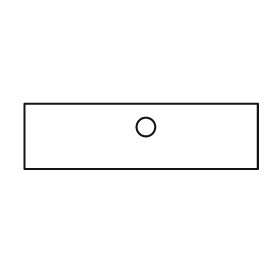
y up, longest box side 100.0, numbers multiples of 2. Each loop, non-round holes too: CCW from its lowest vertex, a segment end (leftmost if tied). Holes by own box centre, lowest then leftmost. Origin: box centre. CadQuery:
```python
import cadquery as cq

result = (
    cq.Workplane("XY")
    .moveTo(-50.0, -14.0)
    .lineTo(50.0, -14.0)
    .lineTo(50.0, 14.0)
    .lineTo(-50.0, 14.0)
    .close()
    .moveTo(2.0, 4.0)
    .circle(4.0)
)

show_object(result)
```